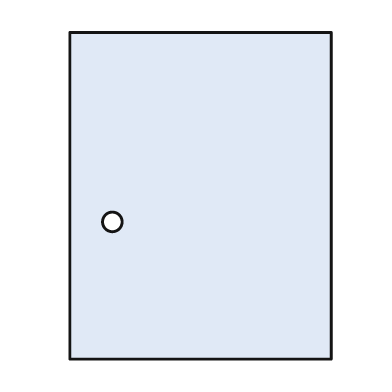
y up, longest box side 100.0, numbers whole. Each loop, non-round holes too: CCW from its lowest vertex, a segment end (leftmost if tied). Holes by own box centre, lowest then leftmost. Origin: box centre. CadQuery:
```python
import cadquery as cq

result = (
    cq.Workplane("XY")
    .moveTo(-40.0, -50.0)
    .lineTo(40.0, -50.0)
    .lineTo(40.0, 50.0)
    .lineTo(-40.0, 50.0)
    .close()
    .moveTo(-27.0, -8.0)
    .circle(3.0)
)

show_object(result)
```